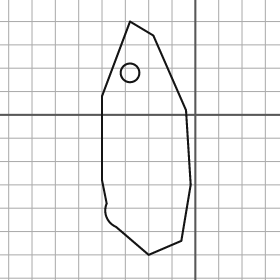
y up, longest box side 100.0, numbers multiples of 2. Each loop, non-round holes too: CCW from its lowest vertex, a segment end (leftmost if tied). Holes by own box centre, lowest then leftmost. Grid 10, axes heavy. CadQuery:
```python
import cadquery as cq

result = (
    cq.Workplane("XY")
    .moveTo(-20.0, -60.0)
    .lineTo(-6.0, -54.0)
    .lineTo(-2.0, -30.0)
    .lineTo(-4.0, 2.0)
    .lineTo(-18.0, 34.0)
    .lineTo(-28.0, 40.0)
    .lineTo(-40.0, 8.0)
    .lineTo(-40.0, -28.0)
    .lineTo(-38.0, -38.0)
    .threePointArc((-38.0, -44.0), (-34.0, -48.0))
    .close()
    .moveTo(-28.0, 18.0)
    .circle(4.0)
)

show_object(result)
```